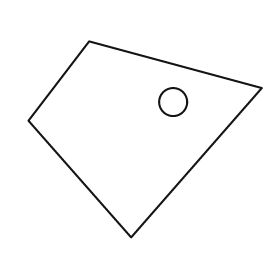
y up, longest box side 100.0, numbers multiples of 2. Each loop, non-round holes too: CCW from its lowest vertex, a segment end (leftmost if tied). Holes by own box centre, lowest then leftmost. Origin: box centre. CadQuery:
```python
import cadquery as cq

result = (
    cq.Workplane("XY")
    .moveTo(-6.0, -42.0)
    .lineTo(50.0, 22.0)
    .lineTo(-24.0, 42.0)
    .lineTo(-50.0, 8.0)
    .close()
    .moveTo(12.0, 16.0)
    .circle(6.0)
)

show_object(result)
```